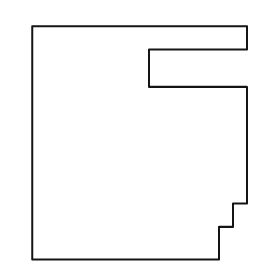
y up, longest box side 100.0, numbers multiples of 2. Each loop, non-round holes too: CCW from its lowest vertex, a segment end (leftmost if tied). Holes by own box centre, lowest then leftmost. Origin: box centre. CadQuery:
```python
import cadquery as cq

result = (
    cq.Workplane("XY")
    .moveTo(-46.0, -50.0)
    .lineTo(34.0, -50.0)
    .lineTo(34.0, -36.0)
    .lineTo(40.0, -36.0)
    .lineTo(40.0, -26.0)
    .lineTo(46.0, -26.0)
    .lineTo(46.0, 24.0)
    .lineTo(4.0, 24.0)
    .lineTo(4.0, 40.0)
    .lineTo(46.0, 40.0)
    .lineTo(46.0, 50.0)
    .lineTo(-46.0, 50.0)
    .close()
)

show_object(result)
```